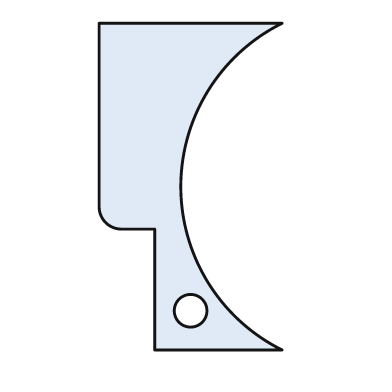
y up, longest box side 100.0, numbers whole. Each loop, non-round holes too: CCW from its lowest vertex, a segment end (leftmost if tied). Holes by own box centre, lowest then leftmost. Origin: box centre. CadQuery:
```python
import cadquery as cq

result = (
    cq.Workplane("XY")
    .moveTo(-11.0, -50.0)
    .lineTo(28.0, -50.0)
    .threePointArc((-3.0, 0.0), (28.0, 50.0))
    .lineTo(-28.0, 50.0)
    .lineTo(-28.0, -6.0)
    .threePointArc((-26.0, -11.0), (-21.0, -13.0))
    .lineTo(-11.0, -13.0)
    .close()
    .moveTo(0.0, -38.0)
    .circle(5.0)
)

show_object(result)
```